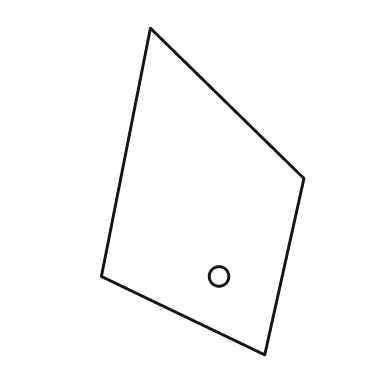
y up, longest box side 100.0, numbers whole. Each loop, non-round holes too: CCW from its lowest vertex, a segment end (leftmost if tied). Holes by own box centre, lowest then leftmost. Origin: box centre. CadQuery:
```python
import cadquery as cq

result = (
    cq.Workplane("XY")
    .moveTo(19.0, -50.0)
    .lineTo(31.0, 4.0)
    .lineTo(-16.0, 50.0)
    .lineTo(-31.0, -26.0)
    .close()
    .moveTo(5.0, -26.0)
    .circle(3.0)
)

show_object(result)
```